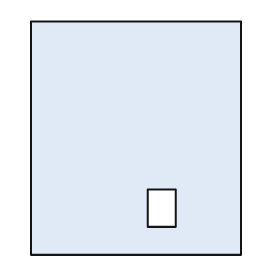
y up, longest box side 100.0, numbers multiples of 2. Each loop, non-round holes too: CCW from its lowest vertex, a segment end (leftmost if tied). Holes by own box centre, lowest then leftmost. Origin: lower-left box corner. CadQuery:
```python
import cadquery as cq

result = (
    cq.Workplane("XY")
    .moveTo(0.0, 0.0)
    .lineTo(90.0, 0.0)
    .lineTo(90.0, 100.0)
    .lineTo(0.0, 100.0)
    .close()
    .moveTo(50.0, 12.0)
    .lineTo(62.0, 12.0)
    .lineTo(62.0, 28.0)
    .lineTo(50.0, 28.0)
    .close()
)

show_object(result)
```